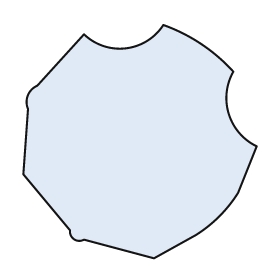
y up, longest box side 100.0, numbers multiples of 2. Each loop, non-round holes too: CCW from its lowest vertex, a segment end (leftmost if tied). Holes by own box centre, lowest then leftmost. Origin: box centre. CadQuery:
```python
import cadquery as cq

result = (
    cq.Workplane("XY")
    .moveTo(6.0, -50.0)
    .lineTo(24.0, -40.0)
    .threePointArc((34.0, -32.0), (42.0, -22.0))
    .lineTo(50.0, -2.0)
    .threePointArc((38.0, 12.0), (40.0, 30.0))
    .threePointArc((26.0, 42.0), (10.0, 50.0))
    .threePointArc((-6.0, 40.0), (-24.0, 46.0))
    .lineTo(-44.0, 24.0)
    .threePointArc((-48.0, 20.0), (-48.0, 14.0))
    .lineTo(-50.0, -14.0)
    .lineTo(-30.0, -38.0)
    .threePointArc((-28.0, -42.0), (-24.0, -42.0))
    .close()
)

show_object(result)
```